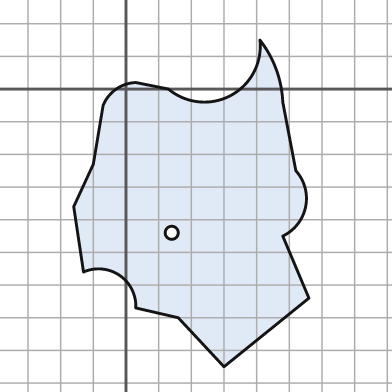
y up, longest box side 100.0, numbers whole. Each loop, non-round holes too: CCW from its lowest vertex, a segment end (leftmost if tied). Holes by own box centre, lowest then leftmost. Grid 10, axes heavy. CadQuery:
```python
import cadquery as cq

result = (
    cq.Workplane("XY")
    .moveTo(30.0, -85.0)
    .lineTo(56.0, -64.0)
    .lineTo(48.0, -45.0)
    .threePointArc((55.0, -36.0), (52.0, -25.0))
    .lineTo(48.0, -4.0)
    .threePointArc((46.0, 6.0), (41.0, 15.0))
    .threePointArc((32.0, -2.0), (13.0, 0.0))
    .lineTo(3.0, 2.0)
    .threePointArc((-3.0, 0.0), (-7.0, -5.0))
    .lineTo(-10.0, -23.0)
    .lineTo(-16.0, -36.0)
    .lineTo(-13.0, -56.0)
    .threePointArc((-2.0, -57.0), (3.0, -67.0))
    .lineTo(16.0, -70.0)
    .close()
    .moveTo(14.0, -44.0)
    .circle(2.0)
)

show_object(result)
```